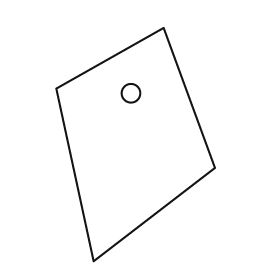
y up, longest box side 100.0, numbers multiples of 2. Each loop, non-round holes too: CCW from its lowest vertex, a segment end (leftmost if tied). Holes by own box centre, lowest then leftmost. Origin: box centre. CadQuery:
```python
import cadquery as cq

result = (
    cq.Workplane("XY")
    .moveTo(-18.0, -50.0)
    .lineTo(34.0, -10.0)
    .lineTo(12.0, 50.0)
    .lineTo(-34.0, 24.0)
    .close()
    .moveTo(-2.0, 22.0)
    .circle(4.0)
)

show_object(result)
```